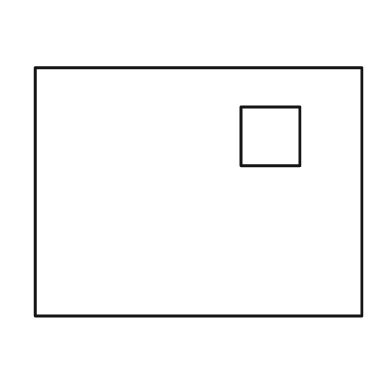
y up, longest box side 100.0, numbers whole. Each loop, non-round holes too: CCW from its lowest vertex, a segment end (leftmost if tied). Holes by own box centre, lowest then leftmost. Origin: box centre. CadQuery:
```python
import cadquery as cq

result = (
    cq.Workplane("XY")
    .moveTo(-50.0, -38.0)
    .lineTo(50.0, -38.0)
    .lineTo(50.0, 38.0)
    .lineTo(-50.0, 38.0)
    .close()
    .moveTo(13.0, 8.0)
    .lineTo(31.0, 8.0)
    .lineTo(31.0, 26.0)
    .lineTo(13.0, 26.0)
    .close()
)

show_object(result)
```